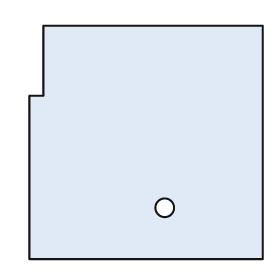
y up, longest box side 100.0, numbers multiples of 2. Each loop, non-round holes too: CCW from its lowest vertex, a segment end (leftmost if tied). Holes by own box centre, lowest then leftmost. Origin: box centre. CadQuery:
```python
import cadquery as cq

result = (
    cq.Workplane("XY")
    .moveTo(-50.0, -50.0)
    .lineTo(50.0, -50.0)
    .lineTo(50.0, 50.0)
    .lineTo(-44.0, 50.0)
    .lineTo(-44.0, 20.0)
    .lineTo(-50.0, 20.0)
    .close()
    .moveTo(8.0, -28.0)
    .circle(4.0)
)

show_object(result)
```